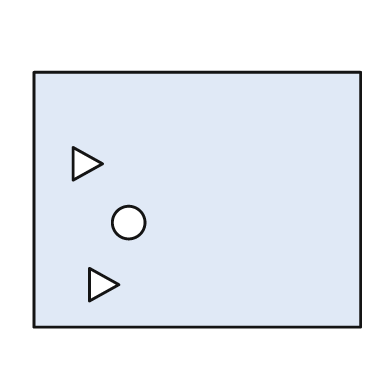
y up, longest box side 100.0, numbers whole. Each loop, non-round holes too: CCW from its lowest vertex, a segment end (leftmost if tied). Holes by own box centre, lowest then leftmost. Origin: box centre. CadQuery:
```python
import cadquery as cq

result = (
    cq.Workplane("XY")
    .moveTo(-50.0, -39.0)
    .lineTo(50.0, -39.0)
    .lineTo(50.0, 39.0)
    .lineTo(-50.0, 39.0)
    .close()
    .moveTo(-33.0, -31.0)
    .lineTo(-24.0, -26.0)
    .lineTo(-33.0, -21.0)
    .close()
    .moveTo(-21.0, -7.0)
    .circle(5.0)
    .moveTo(-38.0, 6.0)
    .lineTo(-29.0, 11.0)
    .lineTo(-38.0, 16.0)
    .close()
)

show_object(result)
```